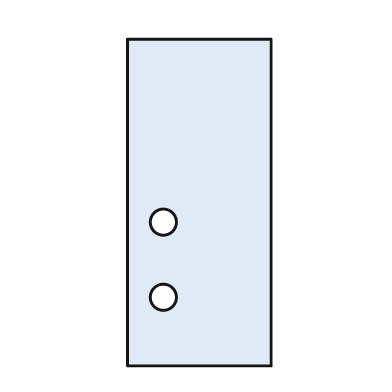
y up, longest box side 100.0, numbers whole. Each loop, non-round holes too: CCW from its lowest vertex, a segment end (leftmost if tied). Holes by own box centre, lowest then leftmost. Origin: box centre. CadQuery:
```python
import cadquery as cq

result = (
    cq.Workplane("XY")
    .moveTo(-22.0, -50.0)
    .lineTo(22.0, -50.0)
    .lineTo(22.0, 50.0)
    .lineTo(-22.0, 50.0)
    .close()
    .moveTo(-11.0, -29.0)
    .circle(4.0)
    .moveTo(-11.0, -6.0)
    .circle(4.0)
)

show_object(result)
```